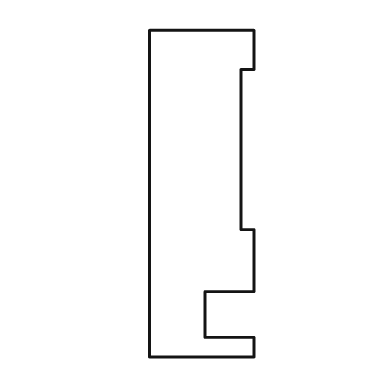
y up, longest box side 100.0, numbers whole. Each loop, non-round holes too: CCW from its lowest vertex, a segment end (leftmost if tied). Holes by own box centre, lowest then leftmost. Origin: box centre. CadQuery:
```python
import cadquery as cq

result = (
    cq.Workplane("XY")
    .moveTo(-16.0, -50.0)
    .lineTo(16.0, -50.0)
    .lineTo(16.0, -44.0)
    .lineTo(1.0, -44.0)
    .lineTo(1.0, -30.0)
    .lineTo(16.0, -30.0)
    .lineTo(16.0, -11.0)
    .lineTo(12.0, -11.0)
    .lineTo(12.0, 38.0)
    .lineTo(16.0, 38.0)
    .lineTo(16.0, 50.0)
    .lineTo(-16.0, 50.0)
    .close()
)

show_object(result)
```